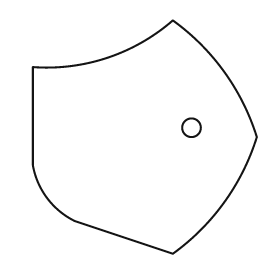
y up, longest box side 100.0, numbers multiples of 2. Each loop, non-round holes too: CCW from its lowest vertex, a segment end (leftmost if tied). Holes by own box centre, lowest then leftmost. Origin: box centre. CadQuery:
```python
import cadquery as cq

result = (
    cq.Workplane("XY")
    .moveTo(12.0, -50.0)
    .threePointArc((34.0, -28.0), (48.0, 0.0))
    .threePointArc((34.0, 28.0), (12.0, 50.0))
    .threePointArc((-16.0, 34.0), (-48.0, 30.0))
    .lineTo(-48.0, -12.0)
    .threePointArc((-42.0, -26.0), (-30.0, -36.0))
    .close()
    .moveTo(20.0, 4.0)
    .circle(4.0)
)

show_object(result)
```